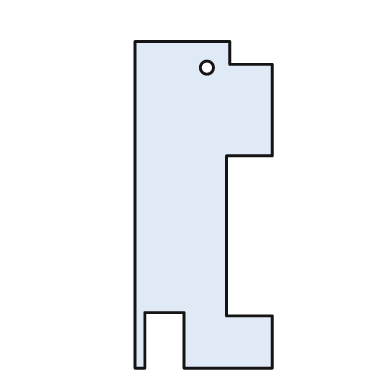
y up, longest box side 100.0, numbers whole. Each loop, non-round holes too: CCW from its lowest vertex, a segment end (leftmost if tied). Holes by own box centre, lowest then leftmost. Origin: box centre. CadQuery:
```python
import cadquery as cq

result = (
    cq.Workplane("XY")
    .moveTo(-21.0, -50.0)
    .lineTo(-18.0, -50.0)
    .lineTo(-18.0, -33.0)
    .lineTo(-6.0, -33.0)
    .lineTo(-6.0, -50.0)
    .lineTo(21.0, -50.0)
    .lineTo(21.0, -34.0)
    .lineTo(7.0, -34.0)
    .lineTo(7.0, 15.0)
    .lineTo(21.0, 15.0)
    .lineTo(21.0, 43.0)
    .lineTo(8.0, 43.0)
    .lineTo(8.0, 50.0)
    .lineTo(-21.0, 50.0)
    .close()
    .moveTo(1.0, 42.0)
    .circle(2.0)
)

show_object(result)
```